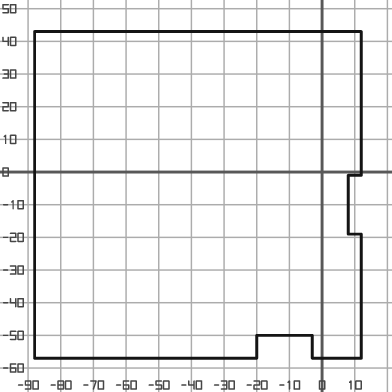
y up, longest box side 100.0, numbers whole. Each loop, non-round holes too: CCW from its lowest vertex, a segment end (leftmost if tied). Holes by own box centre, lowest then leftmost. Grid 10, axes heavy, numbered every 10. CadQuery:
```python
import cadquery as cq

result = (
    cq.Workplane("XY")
    .moveTo(-88.0, -57.0)
    .lineTo(-20.0, -57.0)
    .lineTo(-20.0, -50.0)
    .lineTo(-3.0, -50.0)
    .lineTo(-3.0, -57.0)
    .lineTo(12.0, -57.0)
    .lineTo(12.0, -19.0)
    .lineTo(8.0, -19.0)
    .lineTo(8.0, -1.0)
    .lineTo(12.0, -1.0)
    .lineTo(12.0, 43.0)
    .lineTo(-88.0, 43.0)
    .close()
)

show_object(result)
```